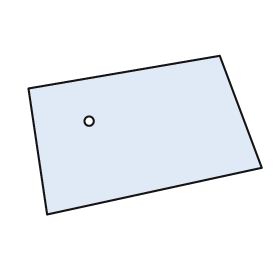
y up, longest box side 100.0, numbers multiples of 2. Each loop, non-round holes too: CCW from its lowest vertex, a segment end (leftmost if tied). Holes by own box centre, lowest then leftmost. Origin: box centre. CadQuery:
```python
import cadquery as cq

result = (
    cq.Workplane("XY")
    .moveTo(-42.0, -34.0)
    .lineTo(50.0, -14.0)
    .lineTo(32.0, 34.0)
    .lineTo(-50.0, 20.0)
    .close()
    .moveTo(-24.0, 6.0)
    .circle(2.0)
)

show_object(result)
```